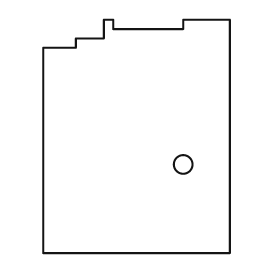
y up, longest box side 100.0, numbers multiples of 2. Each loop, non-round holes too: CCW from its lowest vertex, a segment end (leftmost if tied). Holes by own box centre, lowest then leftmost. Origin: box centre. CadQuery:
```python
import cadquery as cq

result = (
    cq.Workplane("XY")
    .moveTo(-40.0, -50.0)
    .lineTo(40.0, -50.0)
    .lineTo(40.0, 50.0)
    .lineTo(20.0, 50.0)
    .lineTo(20.0, 46.0)
    .lineTo(-10.0, 46.0)
    .lineTo(-10.0, 50.0)
    .lineTo(-14.0, 50.0)
    .lineTo(-14.0, 42.0)
    .lineTo(-26.0, 42.0)
    .lineTo(-26.0, 38.0)
    .lineTo(-40.0, 38.0)
    .close()
    .moveTo(20.0, -12.0)
    .circle(4.0)
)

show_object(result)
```